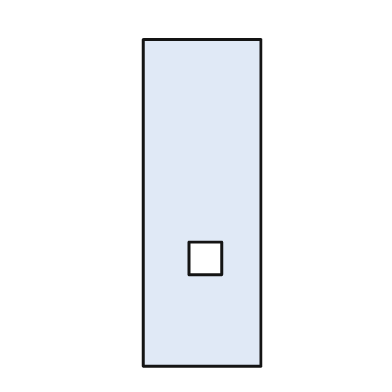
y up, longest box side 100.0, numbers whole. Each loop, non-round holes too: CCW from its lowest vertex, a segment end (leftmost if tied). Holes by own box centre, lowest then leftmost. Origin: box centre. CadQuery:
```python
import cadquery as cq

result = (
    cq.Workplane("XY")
    .moveTo(-18.0, -50.0)
    .lineTo(18.0, -50.0)
    .lineTo(18.0, 50.0)
    .lineTo(-18.0, 50.0)
    .close()
    .moveTo(-4.0, -22.0)
    .lineTo(6.0, -22.0)
    .lineTo(6.0, -12.0)
    .lineTo(-4.0, -12.0)
    .close()
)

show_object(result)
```